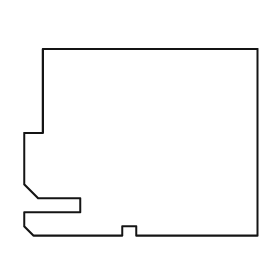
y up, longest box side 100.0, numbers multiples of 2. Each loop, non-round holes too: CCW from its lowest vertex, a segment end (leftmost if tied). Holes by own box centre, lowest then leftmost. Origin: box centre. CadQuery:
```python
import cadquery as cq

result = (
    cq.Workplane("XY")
    .moveTo(-46.0, -40.0)
    .lineTo(-8.0, -40.0)
    .lineTo(-8.0, -36.0)
    .lineTo(-2.0, -36.0)
    .lineTo(-2.0, -40.0)
    .lineTo(50.0, -40.0)
    .lineTo(50.0, 40.0)
    .lineTo(-42.0, 40.0)
    .lineTo(-42.0, 4.0)
    .lineTo(-50.0, 4.0)
    .lineTo(-50.0, -18.0)
    .lineTo(-44.0, -24.0)
    .lineTo(-26.0, -24.0)
    .lineTo(-26.0, -30.0)
    .lineTo(-50.0, -30.0)
    .lineTo(-50.0, -36.0)
    .close()
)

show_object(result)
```